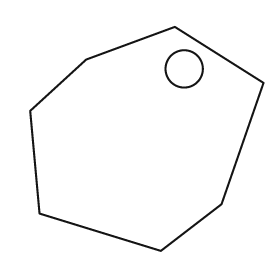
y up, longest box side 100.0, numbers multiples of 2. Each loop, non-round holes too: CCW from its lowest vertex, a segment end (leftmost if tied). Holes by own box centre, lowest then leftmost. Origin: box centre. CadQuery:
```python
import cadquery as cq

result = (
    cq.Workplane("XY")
    .moveTo(6.0, -48.0)
    .lineTo(32.0, -28.0)
    .lineTo(50.0, 24.0)
    .lineTo(12.0, 48.0)
    .lineTo(-26.0, 34.0)
    .lineTo(-50.0, 12.0)
    .lineTo(-46.0, -32.0)
    .close()
    .moveTo(16.0, 30.0)
    .circle(8.0)
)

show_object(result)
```